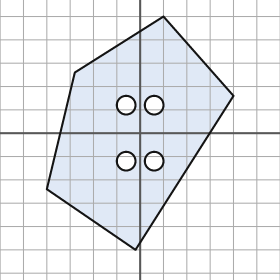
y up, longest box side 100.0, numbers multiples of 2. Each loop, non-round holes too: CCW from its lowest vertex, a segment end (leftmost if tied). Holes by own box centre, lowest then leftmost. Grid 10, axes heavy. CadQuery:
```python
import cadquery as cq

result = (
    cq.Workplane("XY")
    .moveTo(-2.0, -50.0)
    .lineTo(40.0, 16.0)
    .lineTo(10.0, 50.0)
    .lineTo(-28.0, 26.0)
    .lineTo(-40.0, -24.0)
    .close()
    .moveTo(-6.0, -12.0)
    .circle(4.0)
    .moveTo(6.0, -12.0)
    .circle(4.0)
    .moveTo(-6.0, 12.0)
    .circle(4.0)
    .moveTo(6.0, 12.0)
    .circle(4.0)
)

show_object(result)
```